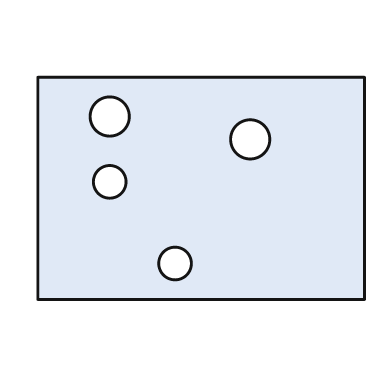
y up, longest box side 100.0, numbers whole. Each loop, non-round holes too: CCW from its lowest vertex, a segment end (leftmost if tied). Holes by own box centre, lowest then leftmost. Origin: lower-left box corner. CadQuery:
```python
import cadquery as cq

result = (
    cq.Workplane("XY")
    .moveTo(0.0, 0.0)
    .lineTo(100.0, 0.0)
    .lineTo(100.0, 68.0)
    .lineTo(0.0, 68.0)
    .close()
    .moveTo(42.0, 11.0)
    .circle(5.0)
    .moveTo(22.0, 36.0)
    .circle(5.0)
    .moveTo(65.0, 49.0)
    .circle(6.0)
    .moveTo(22.0, 56.0)
    .circle(6.0)
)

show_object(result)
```